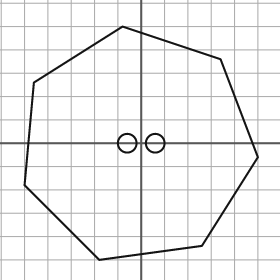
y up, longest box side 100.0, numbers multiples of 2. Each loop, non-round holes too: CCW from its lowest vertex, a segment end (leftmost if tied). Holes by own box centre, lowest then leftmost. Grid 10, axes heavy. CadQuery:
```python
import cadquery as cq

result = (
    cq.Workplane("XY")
    .moveTo(-18.0, -50.0)
    .lineTo(26.0, -44.0)
    .lineTo(50.0, -6.0)
    .lineTo(34.0, 36.0)
    .lineTo(-8.0, 50.0)
    .lineTo(-46.0, 26.0)
    .lineTo(-50.0, -18.0)
    .close()
    .moveTo(-6.0, 0.0)
    .circle(4.0)
    .moveTo(6.0, 0.0)
    .circle(4.0)
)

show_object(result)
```